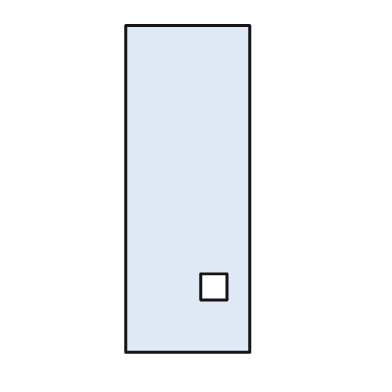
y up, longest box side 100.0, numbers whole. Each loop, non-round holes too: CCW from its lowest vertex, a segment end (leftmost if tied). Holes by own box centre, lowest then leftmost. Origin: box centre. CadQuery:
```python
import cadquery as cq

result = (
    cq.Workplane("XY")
    .moveTo(-19.0, -50.0)
    .lineTo(19.0, -50.0)
    .lineTo(19.0, 50.0)
    .lineTo(-19.0, 50.0)
    .close()
    .moveTo(4.0, -34.0)
    .lineTo(12.0, -34.0)
    .lineTo(12.0, -26.0)
    .lineTo(4.0, -26.0)
    .close()
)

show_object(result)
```